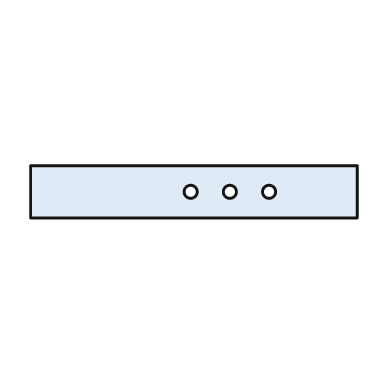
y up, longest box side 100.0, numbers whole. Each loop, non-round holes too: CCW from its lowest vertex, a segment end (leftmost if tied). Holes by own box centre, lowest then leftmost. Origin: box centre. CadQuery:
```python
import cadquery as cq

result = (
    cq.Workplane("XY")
    .moveTo(-50.0, -8.0)
    .lineTo(50.0, -8.0)
    .lineTo(50.0, 8.0)
    .lineTo(-50.0, 8.0)
    .close()
    .moveTo(-1.0, 0.0)
    .circle(2.0)
    .moveTo(11.0, 0.0)
    .circle(2.0)
    .moveTo(23.0, 0.0)
    .circle(2.0)
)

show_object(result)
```